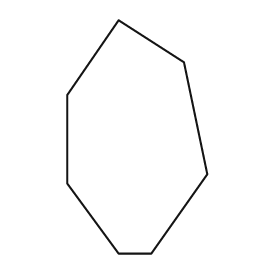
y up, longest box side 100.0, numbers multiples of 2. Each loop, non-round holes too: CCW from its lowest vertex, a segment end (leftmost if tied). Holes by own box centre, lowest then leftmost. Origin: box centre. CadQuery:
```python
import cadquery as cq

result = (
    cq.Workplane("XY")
    .moveTo(-8.0, -50.0)
    .lineTo(6.0, -50.0)
    .lineTo(30.0, -16.0)
    .lineTo(20.0, 32.0)
    .lineTo(-8.0, 50.0)
    .lineTo(-30.0, 18.0)
    .lineTo(-30.0, -20.0)
    .close()
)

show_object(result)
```